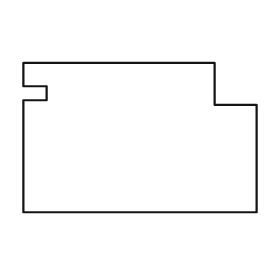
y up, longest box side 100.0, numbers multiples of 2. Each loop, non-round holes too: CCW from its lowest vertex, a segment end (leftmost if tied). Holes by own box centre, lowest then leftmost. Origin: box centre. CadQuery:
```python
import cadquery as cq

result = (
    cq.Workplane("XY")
    .moveTo(-50.0, -32.0)
    .lineTo(50.0, -32.0)
    .lineTo(50.0, 14.0)
    .lineTo(32.0, 14.0)
    .lineTo(32.0, 32.0)
    .lineTo(-50.0, 32.0)
    .lineTo(-50.0, 22.0)
    .lineTo(-40.0, 22.0)
    .lineTo(-40.0, 16.0)
    .lineTo(-50.0, 16.0)
    .close()
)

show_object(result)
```